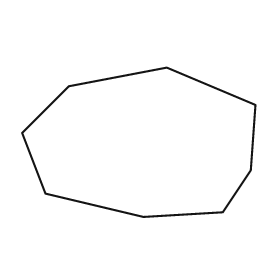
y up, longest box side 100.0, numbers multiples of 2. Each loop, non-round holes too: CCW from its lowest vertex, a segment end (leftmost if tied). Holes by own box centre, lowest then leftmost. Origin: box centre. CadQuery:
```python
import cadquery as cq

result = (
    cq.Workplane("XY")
    .moveTo(2.0, -32.0)
    .lineTo(36.0, -30.0)
    .lineTo(48.0, -12.0)
    .lineTo(50.0, 16.0)
    .lineTo(12.0, 32.0)
    .lineTo(-30.0, 24.0)
    .lineTo(-50.0, 4.0)
    .lineTo(-40.0, -22.0)
    .close()
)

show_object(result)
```